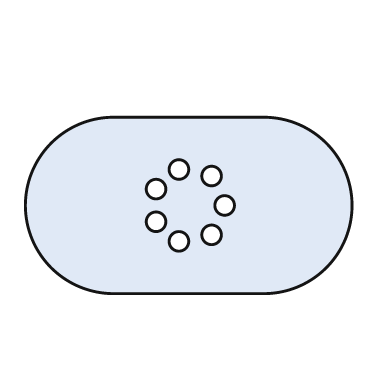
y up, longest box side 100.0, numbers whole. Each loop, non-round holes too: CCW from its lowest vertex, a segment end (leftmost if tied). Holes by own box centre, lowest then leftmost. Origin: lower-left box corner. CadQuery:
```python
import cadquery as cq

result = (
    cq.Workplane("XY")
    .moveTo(27.0, 0.0)
    .lineTo(73.0, 0.0)
    .threePointArc((100.0, 27.0), (73.0, 54.0))
    .lineTo(27.0, 54.0)
    .threePointArc((0.0, 27.0), (27.0, 0.0))
    .close()
    .moveTo(47.0, 16.0)
    .circle(3.0)
    .moveTo(57.0, 18.0)
    .circle(3.0)
    .moveTo(40.0, 22.0)
    .circle(3.0)
    .moveTo(61.0, 27.0)
    .circle(3.0)
    .moveTo(40.0, 32.0)
    .circle(3.0)
    .moveTo(57.0, 36.0)
    .circle(3.0)
    .moveTo(47.0, 38.0)
    .circle(3.0)
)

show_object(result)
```